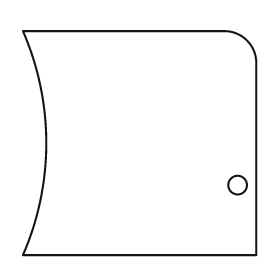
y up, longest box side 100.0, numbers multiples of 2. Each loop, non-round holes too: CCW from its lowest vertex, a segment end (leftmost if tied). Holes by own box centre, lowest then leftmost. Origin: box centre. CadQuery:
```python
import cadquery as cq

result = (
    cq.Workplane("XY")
    .moveTo(-50.0, -48.0)
    .lineTo(50.0, -48.0)
    .lineTo(50.0, 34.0)
    .threePointArc((46.0, 44.0), (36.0, 48.0))
    .lineTo(-50.0, 48.0)
    .threePointArc((-40.0, 0.0), (-50.0, -48.0))
    .close()
    .moveTo(42.0, -18.0)
    .circle(4.0)
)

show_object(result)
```